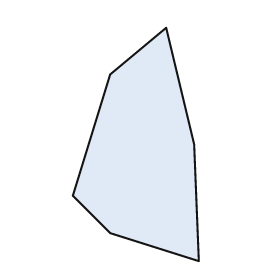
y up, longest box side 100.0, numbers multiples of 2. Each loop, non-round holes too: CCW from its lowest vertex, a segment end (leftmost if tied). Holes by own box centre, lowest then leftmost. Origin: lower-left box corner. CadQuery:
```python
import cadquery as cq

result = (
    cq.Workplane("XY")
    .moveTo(54.0, 0.0)
    .lineTo(52.0, 50.0)
    .lineTo(40.0, 100.0)
    .lineTo(16.0, 80.0)
    .lineTo(0.0, 28.0)
    .lineTo(16.0, 12.0)
    .close()
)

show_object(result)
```